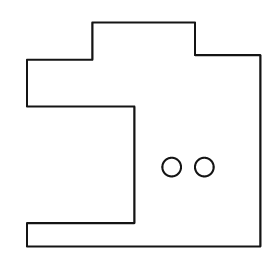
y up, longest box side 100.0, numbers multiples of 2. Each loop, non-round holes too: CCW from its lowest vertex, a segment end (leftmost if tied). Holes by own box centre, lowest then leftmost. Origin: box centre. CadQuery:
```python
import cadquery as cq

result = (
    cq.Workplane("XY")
    .moveTo(-50.0, -48.0)
    .lineTo(50.0, -48.0)
    .lineTo(50.0, 34.0)
    .lineTo(22.0, 34.0)
    .lineTo(22.0, 48.0)
    .lineTo(-22.0, 48.0)
    .lineTo(-22.0, 32.0)
    .lineTo(-50.0, 32.0)
    .lineTo(-50.0, 12.0)
    .lineTo(-4.0, 12.0)
    .lineTo(-4.0, -38.0)
    .lineTo(-50.0, -38.0)
    .close()
    .moveTo(12.0, -14.0)
    .circle(4.0)
    .moveTo(26.0, -14.0)
    .circle(4.0)
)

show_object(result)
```